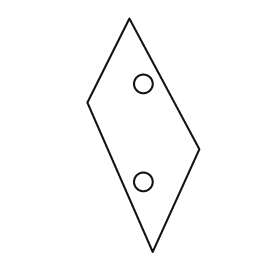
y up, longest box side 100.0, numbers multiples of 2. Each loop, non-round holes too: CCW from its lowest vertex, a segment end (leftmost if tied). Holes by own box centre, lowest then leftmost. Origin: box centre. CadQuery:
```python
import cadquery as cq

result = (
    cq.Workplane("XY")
    .moveTo(4.0, -50.0)
    .lineTo(24.0, -6.0)
    .lineTo(-6.0, 50.0)
    .lineTo(-24.0, 14.0)
    .close()
    .moveTo(0.0, -20.0)
    .circle(4.0)
    .moveTo(0.0, 22.0)
    .circle(4.0)
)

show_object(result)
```